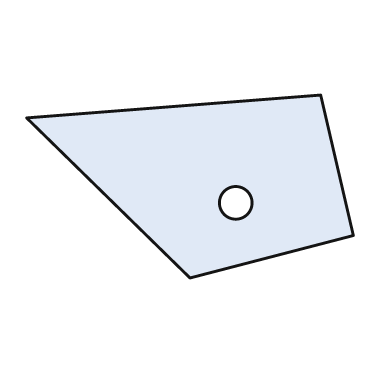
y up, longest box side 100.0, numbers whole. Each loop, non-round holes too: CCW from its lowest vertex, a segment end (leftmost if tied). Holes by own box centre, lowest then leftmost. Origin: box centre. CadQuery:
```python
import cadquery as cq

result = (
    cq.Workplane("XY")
    .moveTo(0.0, -28.0)
    .lineTo(50.0, -15.0)
    .lineTo(40.0, 28.0)
    .lineTo(-50.0, 21.0)
    .close()
    .moveTo(14.0, -5.0)
    .circle(5.0)
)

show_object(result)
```